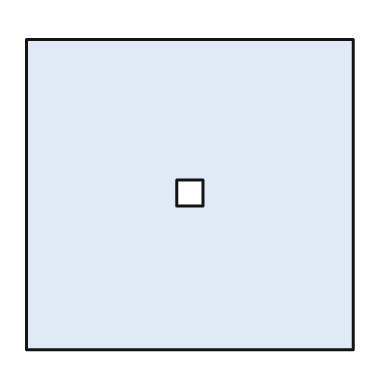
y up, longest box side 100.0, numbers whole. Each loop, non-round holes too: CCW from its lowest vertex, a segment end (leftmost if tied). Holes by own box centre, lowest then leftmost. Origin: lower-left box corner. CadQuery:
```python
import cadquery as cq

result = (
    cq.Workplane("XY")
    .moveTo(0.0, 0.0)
    .lineTo(100.0, 0.0)
    .lineTo(100.0, 95.0)
    .lineTo(0.0, 95.0)
    .close()
    .moveTo(46.0, 44.0)
    .lineTo(54.0, 44.0)
    .lineTo(54.0, 52.0)
    .lineTo(46.0, 52.0)
    .close()
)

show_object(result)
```